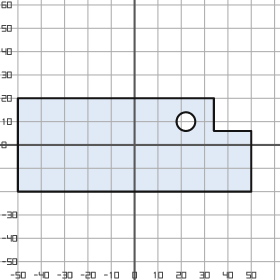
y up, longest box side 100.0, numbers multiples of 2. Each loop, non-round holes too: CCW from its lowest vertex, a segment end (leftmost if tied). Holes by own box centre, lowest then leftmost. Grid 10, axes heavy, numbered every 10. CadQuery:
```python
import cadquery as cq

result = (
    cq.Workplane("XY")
    .moveTo(-50.0, -20.0)
    .lineTo(50.0, -20.0)
    .lineTo(50.0, 6.0)
    .lineTo(34.0, 6.0)
    .lineTo(34.0, 20.0)
    .lineTo(-50.0, 20.0)
    .close()
    .moveTo(22.0, 10.0)
    .circle(4.0)
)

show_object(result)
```